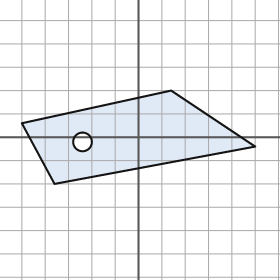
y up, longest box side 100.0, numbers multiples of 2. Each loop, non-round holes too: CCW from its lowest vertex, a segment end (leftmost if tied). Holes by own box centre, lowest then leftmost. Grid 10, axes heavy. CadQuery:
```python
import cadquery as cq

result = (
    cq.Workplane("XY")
    .moveTo(-36.0, -20.0)
    .lineTo(50.0, -4.0)
    .lineTo(14.0, 20.0)
    .lineTo(-50.0, 6.0)
    .close()
    .moveTo(-24.0, -2.0)
    .circle(4.0)
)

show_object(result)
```